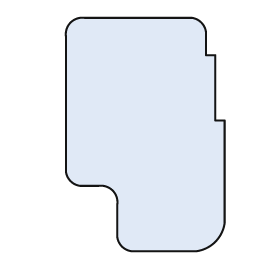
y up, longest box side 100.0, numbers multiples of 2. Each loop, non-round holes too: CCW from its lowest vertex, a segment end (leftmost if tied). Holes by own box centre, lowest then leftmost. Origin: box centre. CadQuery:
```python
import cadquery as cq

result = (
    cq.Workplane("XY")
    .moveTo(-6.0, -50.0)
    .lineTo(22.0, -50.0)
    .threePointArc((30.0, -46.0), (34.0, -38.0))
    .lineTo(34.0, 6.0)
    .lineTo(30.0, 6.0)
    .lineTo(30.0, 34.0)
    .lineTo(26.0, 34.0)
    .lineTo(26.0, 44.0)
    .threePointArc((24.0, 48.0), (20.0, 50.0))
    .lineTo(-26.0, 50.0)
    .threePointArc((-32.0, 48.0), (-34.0, 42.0))
    .lineTo(-34.0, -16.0)
    .threePointArc((-32.0, -20.0), (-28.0, -22.0))
    .lineTo(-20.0, -22.0)
    .threePointArc((-14.0, -24.0), (-12.0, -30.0))
    .lineTo(-12.0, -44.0)
    .threePointArc((-10.0, -48.0), (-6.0, -50.0))
    .close()
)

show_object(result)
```